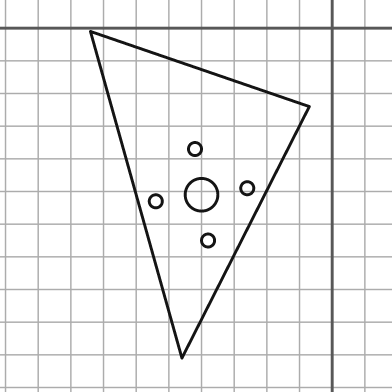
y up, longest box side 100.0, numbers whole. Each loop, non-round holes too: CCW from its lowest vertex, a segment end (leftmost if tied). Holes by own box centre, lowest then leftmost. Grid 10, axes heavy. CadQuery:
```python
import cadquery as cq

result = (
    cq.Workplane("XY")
    .moveTo(-46.0, -101.0)
    .lineTo(-7.0, -24.0)
    .lineTo(-74.0, -1.0)
    .close()
    .moveTo(-38.0, -65.0)
    .circle(2.0)
    .moveTo(-54.0, -53.0)
    .circle(2.0)
    .moveTo(-40.0, -51.0)
    .circle(5.0)
    .moveTo(-26.0, -49.0)
    .circle(2.0)
    .moveTo(-42.0, -37.0)
    .circle(2.0)
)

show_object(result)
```